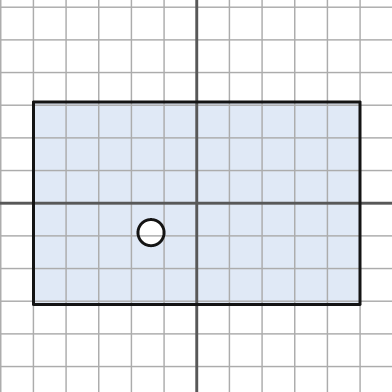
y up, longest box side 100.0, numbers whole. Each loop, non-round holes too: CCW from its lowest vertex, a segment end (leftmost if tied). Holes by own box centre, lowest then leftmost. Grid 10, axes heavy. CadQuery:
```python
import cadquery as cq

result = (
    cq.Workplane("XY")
    .moveTo(-50.0, -31.0)
    .lineTo(50.0, -31.0)
    .lineTo(50.0, 31.0)
    .lineTo(-50.0, 31.0)
    .close()
    .moveTo(-14.0, -9.0)
    .circle(4.0)
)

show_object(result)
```